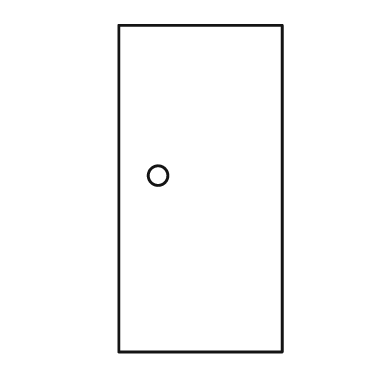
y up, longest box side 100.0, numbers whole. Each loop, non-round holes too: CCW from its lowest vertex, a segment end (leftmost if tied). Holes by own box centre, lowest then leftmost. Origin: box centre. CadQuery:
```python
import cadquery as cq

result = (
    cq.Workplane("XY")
    .moveTo(-25.0, -50.0)
    .lineTo(25.0, -50.0)
    .lineTo(25.0, 50.0)
    .lineTo(-25.0, 50.0)
    .close()
    .moveTo(-13.0, 4.0)
    .circle(3.0)
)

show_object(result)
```